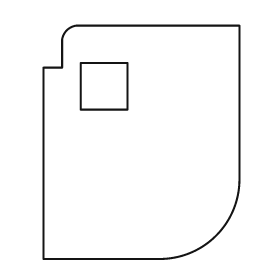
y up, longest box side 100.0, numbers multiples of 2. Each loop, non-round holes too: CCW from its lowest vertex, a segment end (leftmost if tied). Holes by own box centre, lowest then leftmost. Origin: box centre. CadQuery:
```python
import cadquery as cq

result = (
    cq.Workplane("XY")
    .moveTo(-42.0, -50.0)
    .lineTo(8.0, -50.0)
    .threePointArc((32.0, -40.0), (42.0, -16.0))
    .lineTo(42.0, 50.0)
    .lineTo(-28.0, 50.0)
    .threePointArc((-32.0, 48.0), (-34.0, 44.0))
    .lineTo(-34.0, 32.0)
    .lineTo(-42.0, 32.0)
    .close()
    .moveTo(-26.0, 14.0)
    .lineTo(-6.0, 14.0)
    .lineTo(-6.0, 34.0)
    .lineTo(-26.0, 34.0)
    .close()
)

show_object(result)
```